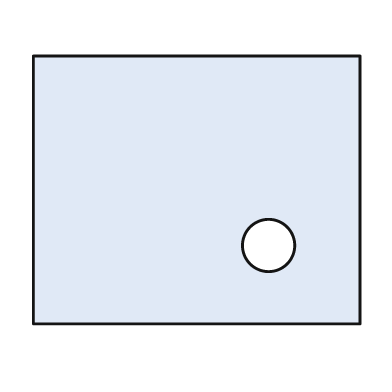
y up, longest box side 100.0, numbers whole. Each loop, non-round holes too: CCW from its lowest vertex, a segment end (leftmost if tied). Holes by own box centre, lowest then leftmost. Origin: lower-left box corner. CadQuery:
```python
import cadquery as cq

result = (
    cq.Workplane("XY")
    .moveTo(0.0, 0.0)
    .lineTo(100.0, 0.0)
    .lineTo(100.0, 82.0)
    .lineTo(0.0, 82.0)
    .close()
    .moveTo(72.0, 24.0)
    .circle(8.0)
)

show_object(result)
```